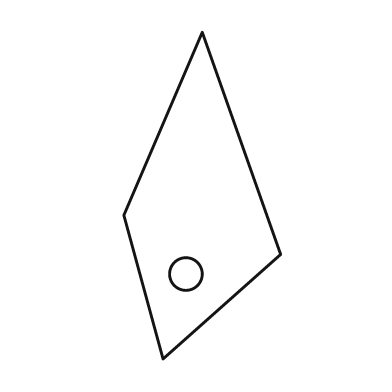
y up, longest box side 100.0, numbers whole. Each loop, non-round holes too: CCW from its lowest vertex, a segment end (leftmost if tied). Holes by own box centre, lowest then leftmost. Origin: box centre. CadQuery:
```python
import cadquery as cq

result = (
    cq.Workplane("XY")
    .moveTo(-12.0, -50.0)
    .lineTo(24.0, -18.0)
    .lineTo(0.0, 50.0)
    .lineTo(-24.0, -6.0)
    .close()
    .moveTo(-5.0, -24.0)
    .circle(5.0)
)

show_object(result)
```